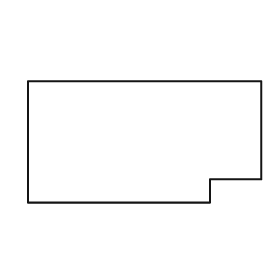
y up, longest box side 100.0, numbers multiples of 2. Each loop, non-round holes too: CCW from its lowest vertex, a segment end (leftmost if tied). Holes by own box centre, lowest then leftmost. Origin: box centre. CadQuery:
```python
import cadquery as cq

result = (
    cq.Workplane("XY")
    .moveTo(-50.0, -26.0)
    .lineTo(28.0, -26.0)
    .lineTo(28.0, -16.0)
    .lineTo(50.0, -16.0)
    .lineTo(50.0, 26.0)
    .lineTo(-50.0, 26.0)
    .close()
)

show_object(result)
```